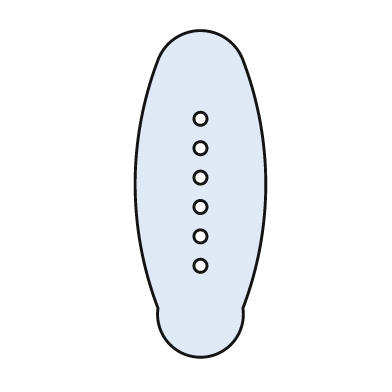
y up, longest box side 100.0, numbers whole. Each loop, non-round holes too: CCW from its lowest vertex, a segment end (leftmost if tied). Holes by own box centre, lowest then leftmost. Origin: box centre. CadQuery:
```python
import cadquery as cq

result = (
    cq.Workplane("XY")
    .moveTo(-13.0, -35.0)
    .threePointArc((0.0, -50.0), (13.0, -35.0))
    .threePointArc((20.0, 3.0), (13.0, 41.0))
    .threePointArc((0.0, 50.0), (-13.0, 41.0))
    .threePointArc((-20.0, 3.0), (-13.0, -35.0))
    .close()
    .moveTo(0.0, -22.0)
    .circle(2.0)
    .moveTo(0.0, -13.0)
    .circle(2.0)
    .moveTo(0.0, -4.0)
    .circle(2.0)
    .moveTo(0.0, 5.0)
    .circle(2.0)
    .moveTo(0.0, 14.0)
    .circle(2.0)
    .moveTo(0.0, 23.0)
    .circle(2.0)
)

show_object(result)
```